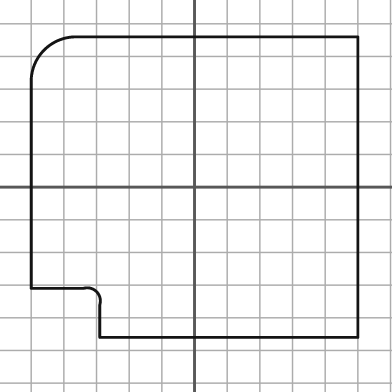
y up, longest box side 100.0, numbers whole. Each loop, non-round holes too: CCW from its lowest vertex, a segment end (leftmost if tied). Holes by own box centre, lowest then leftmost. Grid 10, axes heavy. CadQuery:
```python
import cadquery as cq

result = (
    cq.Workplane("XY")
    .moveTo(-29.0, -46.0)
    .lineTo(50.0, -46.0)
    .lineTo(50.0, 46.0)
    .lineTo(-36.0, 46.0)
    .threePointArc((-46.0, 42.0), (-50.0, 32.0))
    .lineTo(-50.0, -31.0)
    .lineTo(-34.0, -31.0)
    .threePointArc((-30.0, -32.0), (-29.0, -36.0))
    .close()
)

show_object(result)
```